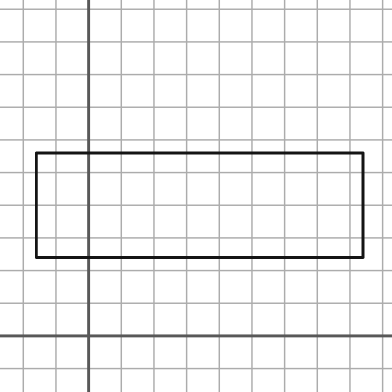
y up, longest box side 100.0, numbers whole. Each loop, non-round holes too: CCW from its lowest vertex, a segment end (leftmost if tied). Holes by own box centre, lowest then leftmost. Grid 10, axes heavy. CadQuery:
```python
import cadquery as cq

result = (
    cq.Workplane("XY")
    .moveTo(-16.0, 24.0)
    .lineTo(84.0, 24.0)
    .lineTo(84.0, 56.0)
    .lineTo(-16.0, 56.0)
    .close()
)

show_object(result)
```